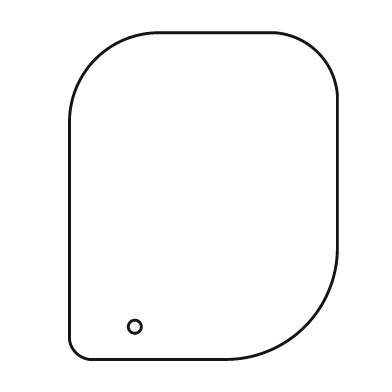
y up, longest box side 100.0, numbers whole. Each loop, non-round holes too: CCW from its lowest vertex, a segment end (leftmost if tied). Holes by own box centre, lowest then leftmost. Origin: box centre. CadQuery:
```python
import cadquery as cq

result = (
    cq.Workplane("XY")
    .moveTo(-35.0, -50.0)
    .lineTo(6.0, -50.0)
    .threePointArc((31.0, -40.0), (41.0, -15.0))
    .lineTo(41.0, 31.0)
    .threePointArc((35.0, 44.0), (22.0, 50.0))
    .lineTo(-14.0, 50.0)
    .threePointArc((-33.0, 42.0), (-41.0, 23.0))
    .lineTo(-41.0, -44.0)
    .threePointArc((-39.0, -48.0), (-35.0, -50.0))
    .close()
    .moveTo(-21.0, -40.0)
    .circle(2.0)
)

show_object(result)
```